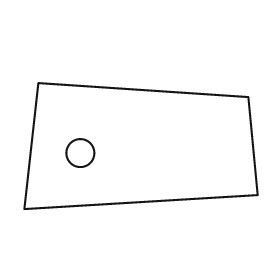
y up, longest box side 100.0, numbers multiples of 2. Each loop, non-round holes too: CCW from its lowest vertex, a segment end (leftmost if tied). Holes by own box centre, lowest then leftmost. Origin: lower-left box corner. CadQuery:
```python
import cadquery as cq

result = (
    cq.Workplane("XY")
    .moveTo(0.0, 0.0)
    .lineTo(100.0, 6.0)
    .lineTo(96.0, 48.0)
    .lineTo(6.0, 54.0)
    .close()
    .moveTo(24.0, 24.0)
    .circle(6.0)
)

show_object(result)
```